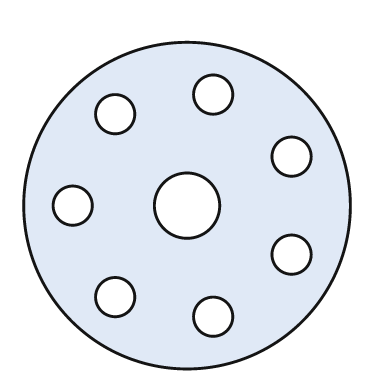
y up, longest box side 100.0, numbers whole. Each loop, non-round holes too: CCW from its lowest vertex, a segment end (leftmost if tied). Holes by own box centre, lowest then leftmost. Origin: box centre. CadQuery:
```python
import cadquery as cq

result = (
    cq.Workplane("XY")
    .moveTo(0.0, 0.0)
    .circle(50.0)
    .moveTo(8.0, -34.0)
    .circle(6.0)
    .moveTo(-22.0, -28.0)
    .circle(6.0)
    .moveTo(32.0, -15.0)
    .circle(6.0)
    .moveTo(-35.0, 0.0)
    .circle(6.0)
    .moveTo(0.0, 0.0)
    .circle(10.0)
    .moveTo(32.0, 15.0)
    .circle(6.0)
    .moveTo(-22.0, 28.0)
    .circle(6.0)
    .moveTo(8.0, 34.0)
    .circle(6.0)
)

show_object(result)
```